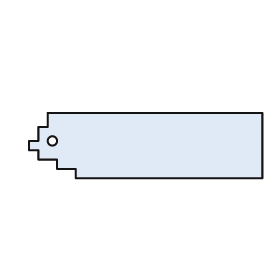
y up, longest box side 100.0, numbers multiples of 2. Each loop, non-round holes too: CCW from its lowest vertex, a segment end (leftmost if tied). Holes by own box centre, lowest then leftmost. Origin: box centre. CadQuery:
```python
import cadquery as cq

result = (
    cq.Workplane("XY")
    .moveTo(-30.0, -14.0)
    .lineTo(50.0, -14.0)
    .lineTo(50.0, 14.0)
    .lineTo(-42.0, 14.0)
    .lineTo(-42.0, 8.0)
    .lineTo(-46.0, 8.0)
    .lineTo(-46.0, 2.0)
    .lineTo(-50.0, 2.0)
    .lineTo(-50.0, -2.0)
    .lineTo(-46.0, -2.0)
    .lineTo(-46.0, -6.0)
    .lineTo(-38.0, -6.0)
    .lineTo(-38.0, -10.0)
    .lineTo(-30.0, -10.0)
    .close()
    .moveTo(-40.0, 2.0)
    .circle(2.0)
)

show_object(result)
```